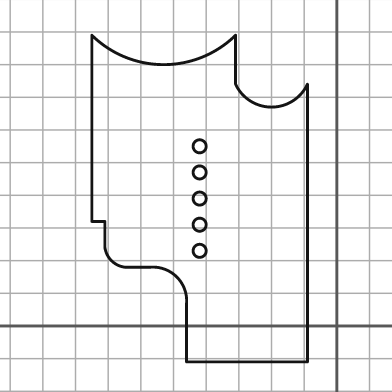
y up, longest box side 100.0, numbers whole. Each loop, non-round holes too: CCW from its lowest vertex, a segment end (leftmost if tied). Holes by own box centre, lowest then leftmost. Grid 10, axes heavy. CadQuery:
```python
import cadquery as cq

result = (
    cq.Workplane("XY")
    .moveTo(-46.0, -11.0)
    .lineTo(-9.0, -11.0)
    .lineTo(-9.0, 74.0)
    .threePointArc((-20.0, 67.0), (-31.0, 74.0))
    .lineTo(-31.0, 89.0)
    .threePointArc((-53.0, 80.0), (-75.0, 89.0))
    .lineTo(-75.0, 32.0)
    .lineTo(-71.0, 32.0)
    .lineTo(-71.0, 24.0)
    .threePointArc((-69.0, 20.0), (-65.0, 18.0))
    .lineTo(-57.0, 18.0)
    .threePointArc((-49.0, 15.0), (-46.0, 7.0))
    .close()
    .moveTo(-42.0, 23.0)
    .circle(2.0)
    .moveTo(-42.0, 31.0)
    .circle(2.0)
    .moveTo(-42.0, 39.0)
    .circle(2.0)
    .moveTo(-42.0, 47.0)
    .circle(2.0)
    .moveTo(-42.0, 55.0)
    .circle(2.0)
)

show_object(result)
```